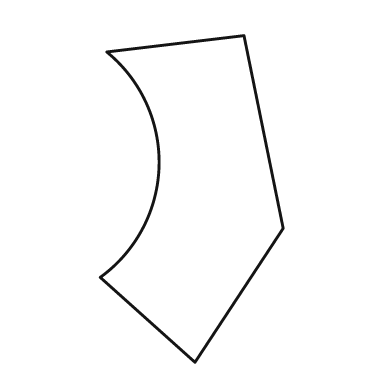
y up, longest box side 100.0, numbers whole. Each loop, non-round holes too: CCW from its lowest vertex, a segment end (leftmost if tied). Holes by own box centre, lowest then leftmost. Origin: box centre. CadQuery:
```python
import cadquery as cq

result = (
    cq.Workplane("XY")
    .moveTo(1.0, -50.0)
    .lineTo(28.0, -9.0)
    .lineTo(16.0, 50.0)
    .lineTo(-26.0, 45.0)
    .threePointArc((-10.0, 10.0), (-28.0, -24.0))
    .close()
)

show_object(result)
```